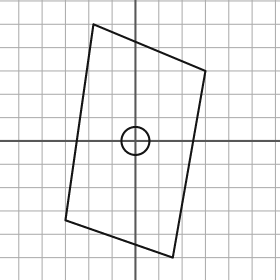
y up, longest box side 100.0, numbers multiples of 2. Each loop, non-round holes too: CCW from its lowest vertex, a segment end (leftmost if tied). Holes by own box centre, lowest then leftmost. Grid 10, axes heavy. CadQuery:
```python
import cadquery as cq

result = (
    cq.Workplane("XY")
    .moveTo(16.0, -50.0)
    .lineTo(30.0, 30.0)
    .lineTo(-18.0, 50.0)
    .lineTo(-30.0, -34.0)
    .close()
    .moveTo(0.0, 0.0)
    .circle(6.0)
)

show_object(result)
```